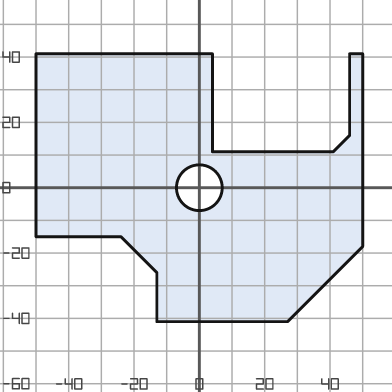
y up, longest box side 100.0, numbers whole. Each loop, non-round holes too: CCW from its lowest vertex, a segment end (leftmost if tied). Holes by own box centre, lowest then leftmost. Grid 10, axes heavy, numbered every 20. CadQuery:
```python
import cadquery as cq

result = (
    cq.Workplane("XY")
    .moveTo(-13.0, -41.0)
    .lineTo(27.0, -41.0)
    .lineTo(50.0, -18.0)
    .lineTo(50.0, 41.0)
    .lineTo(46.0, 41.0)
    .lineTo(46.0, 16.0)
    .lineTo(41.0, 11.0)
    .lineTo(4.0, 11.0)
    .lineTo(4.0, 41.0)
    .lineTo(-50.0, 41.0)
    .lineTo(-50.0, -15.0)
    .lineTo(-24.0, -15.0)
    .lineTo(-13.0, -26.0)
    .close()
    .moveTo(0.0, 0.0)
    .circle(7.0)
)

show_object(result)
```